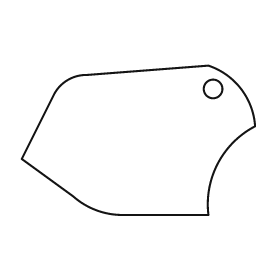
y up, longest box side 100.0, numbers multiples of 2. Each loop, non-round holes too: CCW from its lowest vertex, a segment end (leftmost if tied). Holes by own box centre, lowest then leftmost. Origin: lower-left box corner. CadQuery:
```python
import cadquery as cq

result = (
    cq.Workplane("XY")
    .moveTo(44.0, 0.0)
    .lineTo(80.0, 0.0)
    .threePointArc((84.0, 22.0), (100.0, 38.0))
    .threePointArc((94.0, 54.0), (80.0, 64.0))
    .lineTo(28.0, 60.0)
    .threePointArc((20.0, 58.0), (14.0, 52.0))
    .lineTo(0.0, 24.0)
    .lineTo(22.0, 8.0)
    .threePointArc((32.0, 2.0), (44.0, 0.0))
    .close()
    .moveTo(82.0, 54.0)
    .circle(4.0)
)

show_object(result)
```